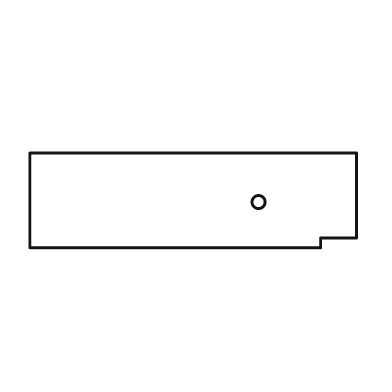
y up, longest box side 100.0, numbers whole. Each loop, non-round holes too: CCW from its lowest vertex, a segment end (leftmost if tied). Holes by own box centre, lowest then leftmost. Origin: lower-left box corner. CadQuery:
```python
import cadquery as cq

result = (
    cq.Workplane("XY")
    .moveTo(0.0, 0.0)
    .lineTo(89.0, 0.0)
    .lineTo(89.0, 3.0)
    .lineTo(100.0, 3.0)
    .lineTo(100.0, 29.0)
    .lineTo(0.0, 29.0)
    .close()
    .moveTo(70.0, 14.0)
    .circle(2.0)
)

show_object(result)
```